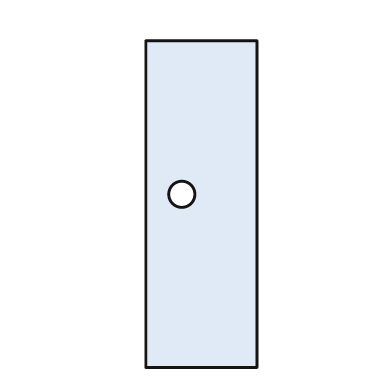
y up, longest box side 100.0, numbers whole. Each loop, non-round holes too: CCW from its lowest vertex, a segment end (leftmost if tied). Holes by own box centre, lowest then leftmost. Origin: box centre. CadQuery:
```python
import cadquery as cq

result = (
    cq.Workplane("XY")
    .moveTo(-17.0, -50.0)
    .lineTo(17.0, -50.0)
    .lineTo(17.0, 50.0)
    .lineTo(-17.0, 50.0)
    .close()
    .moveTo(-6.0, 3.0)
    .circle(4.0)
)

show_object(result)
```